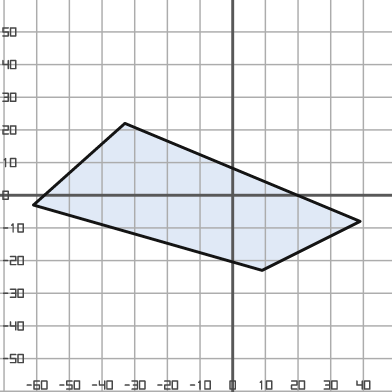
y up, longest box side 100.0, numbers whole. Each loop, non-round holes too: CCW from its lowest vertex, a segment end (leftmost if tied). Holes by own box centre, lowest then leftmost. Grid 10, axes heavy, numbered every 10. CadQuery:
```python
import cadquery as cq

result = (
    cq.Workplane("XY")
    .moveTo(9.0, -23.0)
    .lineTo(39.0, -8.0)
    .lineTo(-33.0, 22.0)
    .lineTo(-61.0, -3.0)
    .close()
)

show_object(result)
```